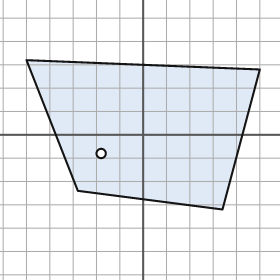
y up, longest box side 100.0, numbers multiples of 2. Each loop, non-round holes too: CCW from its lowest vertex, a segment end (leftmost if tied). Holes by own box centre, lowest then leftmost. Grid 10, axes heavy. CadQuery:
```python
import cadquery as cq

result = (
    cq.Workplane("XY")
    .moveTo(34.0, -32.0)
    .lineTo(50.0, 28.0)
    .lineTo(-50.0, 32.0)
    .lineTo(-28.0, -24.0)
    .close()
    .moveTo(-18.0, -8.0)
    .circle(2.0)
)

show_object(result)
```